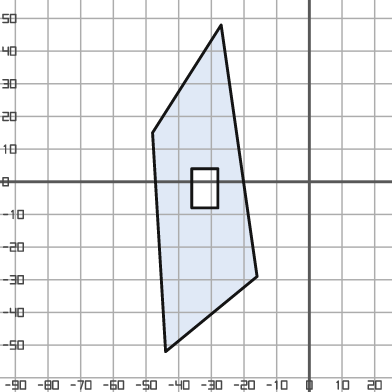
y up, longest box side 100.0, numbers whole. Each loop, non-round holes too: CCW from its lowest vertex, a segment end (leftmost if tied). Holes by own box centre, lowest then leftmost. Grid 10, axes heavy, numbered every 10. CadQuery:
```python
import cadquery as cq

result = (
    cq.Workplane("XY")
    .moveTo(-44.0, -52.0)
    .lineTo(-16.0, -29.0)
    .lineTo(-27.0, 48.0)
    .lineTo(-48.0, 15.0)
    .close()
    .moveTo(-36.0, -8.0)
    .lineTo(-28.0, -8.0)
    .lineTo(-28.0, 4.0)
    .lineTo(-36.0, 4.0)
    .close()
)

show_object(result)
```